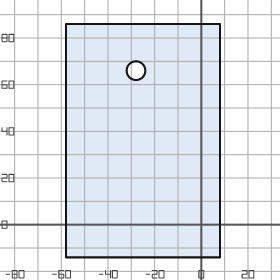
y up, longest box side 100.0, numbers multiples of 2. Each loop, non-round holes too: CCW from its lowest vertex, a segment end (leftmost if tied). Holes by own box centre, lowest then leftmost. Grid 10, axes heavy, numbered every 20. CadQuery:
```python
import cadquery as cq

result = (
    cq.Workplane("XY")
    .moveTo(-58.0, -14.0)
    .lineTo(8.0, -14.0)
    .lineTo(8.0, 86.0)
    .lineTo(-58.0, 86.0)
    .close()
    .moveTo(-28.0, 66.0)
    .circle(4.0)
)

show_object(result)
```